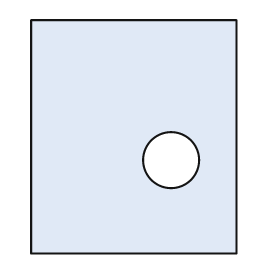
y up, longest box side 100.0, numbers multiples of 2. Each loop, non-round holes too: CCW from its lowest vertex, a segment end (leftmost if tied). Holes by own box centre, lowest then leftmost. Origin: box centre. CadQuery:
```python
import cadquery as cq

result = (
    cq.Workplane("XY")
    .moveTo(-44.0, -50.0)
    .lineTo(44.0, -50.0)
    .lineTo(44.0, 50.0)
    .lineTo(-44.0, 50.0)
    .close()
    .moveTo(16.0, -10.0)
    .circle(12.0)
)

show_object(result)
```